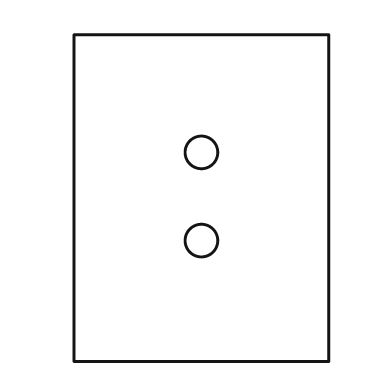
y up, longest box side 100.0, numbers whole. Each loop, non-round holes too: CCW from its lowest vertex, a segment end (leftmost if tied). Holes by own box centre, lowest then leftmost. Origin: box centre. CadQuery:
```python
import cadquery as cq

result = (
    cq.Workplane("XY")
    .moveTo(-39.0, -50.0)
    .lineTo(39.0, -50.0)
    .lineTo(39.0, 50.0)
    .lineTo(-39.0, 50.0)
    .close()
    .moveTo(0.0, -13.0)
    .circle(5.0)
    .moveTo(0.0, 14.0)
    .circle(5.0)
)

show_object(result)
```